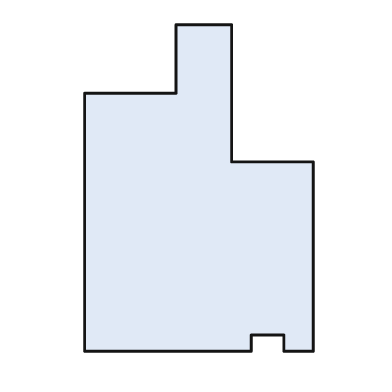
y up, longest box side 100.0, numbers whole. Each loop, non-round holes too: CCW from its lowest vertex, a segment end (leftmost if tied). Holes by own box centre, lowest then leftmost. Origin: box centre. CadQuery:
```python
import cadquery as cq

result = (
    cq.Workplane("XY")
    .moveTo(-35.0, -50.0)
    .lineTo(16.0, -50.0)
    .lineTo(16.0, -45.0)
    .lineTo(26.0, -45.0)
    .lineTo(26.0, -50.0)
    .lineTo(35.0, -50.0)
    .lineTo(35.0, 8.0)
    .lineTo(10.0, 8.0)
    .lineTo(10.0, 50.0)
    .lineTo(-7.0, 50.0)
    .lineTo(-7.0, 29.0)
    .lineTo(-35.0, 29.0)
    .close()
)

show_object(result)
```